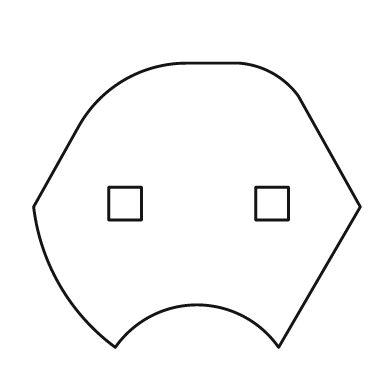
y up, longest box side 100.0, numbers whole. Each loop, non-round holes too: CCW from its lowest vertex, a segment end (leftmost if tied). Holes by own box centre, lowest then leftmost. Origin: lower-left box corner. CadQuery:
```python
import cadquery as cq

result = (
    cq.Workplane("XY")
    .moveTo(25.0, 0.0)
    .threePointArc((50.0, 13.0), (75.0, 0.0))
    .lineTo(100.0, 43.0)
    .lineTo(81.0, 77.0)
    .threePointArc((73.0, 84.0), (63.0, 87.0))
    .lineTo(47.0, 87.0)
    .threePointArc((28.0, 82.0), (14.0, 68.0))
    .lineTo(0.0, 43.0)
    .threePointArc((8.0, 19.0), (25.0, 0.0))
    .close()
    .moveTo(23.0, 39.0)
    .lineTo(33.0, 39.0)
    .lineTo(33.0, 49.0)
    .lineTo(23.0, 49.0)
    .close()
    .moveTo(68.0, 39.0)
    .lineTo(78.0, 39.0)
    .lineTo(78.0, 49.0)
    .lineTo(68.0, 49.0)
    .close()
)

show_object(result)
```